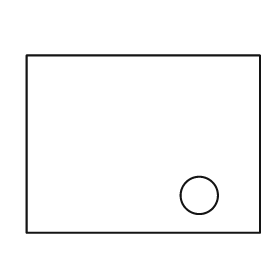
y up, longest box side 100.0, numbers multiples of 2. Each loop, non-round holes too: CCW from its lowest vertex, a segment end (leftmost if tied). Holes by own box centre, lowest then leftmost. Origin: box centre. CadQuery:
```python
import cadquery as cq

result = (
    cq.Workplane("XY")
    .moveTo(-50.0, -38.0)
    .lineTo(50.0, -38.0)
    .lineTo(50.0, 38.0)
    .lineTo(-50.0, 38.0)
    .close()
    .moveTo(24.0, -22.0)
    .circle(8.0)
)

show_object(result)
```